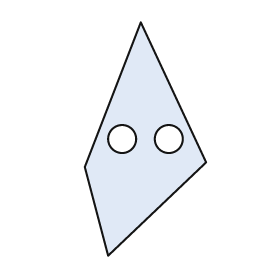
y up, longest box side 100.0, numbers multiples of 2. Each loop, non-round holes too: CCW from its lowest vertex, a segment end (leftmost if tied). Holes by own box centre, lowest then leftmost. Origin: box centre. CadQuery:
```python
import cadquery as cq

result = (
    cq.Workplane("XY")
    .moveTo(-16.0, -50.0)
    .lineTo(26.0, -10.0)
    .lineTo(-2.0, 50.0)
    .lineTo(-26.0, -12.0)
    .close()
    .moveTo(-10.0, 0.0)
    .circle(6.0)
    .moveTo(10.0, 0.0)
    .circle(6.0)
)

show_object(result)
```